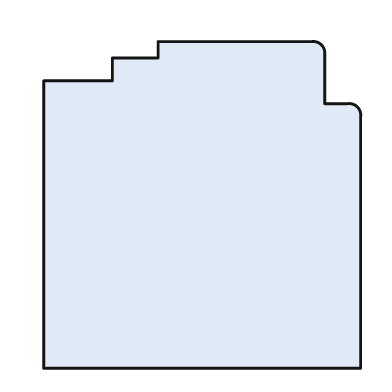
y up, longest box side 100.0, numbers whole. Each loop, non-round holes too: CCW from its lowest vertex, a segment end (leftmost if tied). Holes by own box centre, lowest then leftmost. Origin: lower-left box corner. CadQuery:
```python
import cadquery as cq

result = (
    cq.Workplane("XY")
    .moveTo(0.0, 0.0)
    .lineTo(97.0, 0.0)
    .lineTo(97.0, 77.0)
    .threePointArc((96.0, 80.0), (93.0, 81.0))
    .lineTo(86.0, 81.0)
    .lineTo(86.0, 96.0)
    .threePointArc((85.0, 99.0), (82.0, 100.0))
    .lineTo(35.0, 100.0)
    .lineTo(35.0, 95.0)
    .lineTo(21.0, 95.0)
    .lineTo(21.0, 88.0)
    .lineTo(0.0, 88.0)
    .close()
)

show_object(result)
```